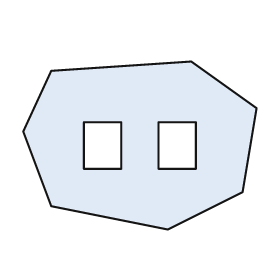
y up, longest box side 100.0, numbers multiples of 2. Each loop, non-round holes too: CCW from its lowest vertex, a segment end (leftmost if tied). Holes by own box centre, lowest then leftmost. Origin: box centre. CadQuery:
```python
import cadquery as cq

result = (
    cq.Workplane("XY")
    .moveTo(12.0, -36.0)
    .lineTo(44.0, -20.0)
    .lineTo(50.0, 16.0)
    .lineTo(22.0, 36.0)
    .lineTo(-38.0, 32.0)
    .lineTo(-50.0, 6.0)
    .lineTo(-38.0, -26.0)
    .close()
    .moveTo(-24.0, -10.0)
    .lineTo(-8.0, -10.0)
    .lineTo(-8.0, 10.0)
    .lineTo(-24.0, 10.0)
    .close()
    .moveTo(8.0, -10.0)
    .lineTo(24.0, -10.0)
    .lineTo(24.0, 10.0)
    .lineTo(8.0, 10.0)
    .close()
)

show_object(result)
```